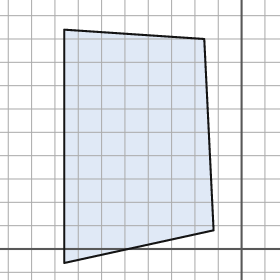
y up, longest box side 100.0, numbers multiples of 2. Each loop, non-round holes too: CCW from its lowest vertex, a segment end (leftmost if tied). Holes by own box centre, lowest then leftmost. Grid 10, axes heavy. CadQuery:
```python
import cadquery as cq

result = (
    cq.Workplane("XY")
    .moveTo(-76.0, -6.0)
    .lineTo(-12.0, 8.0)
    .lineTo(-16.0, 90.0)
    .lineTo(-76.0, 94.0)
    .close()
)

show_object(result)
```